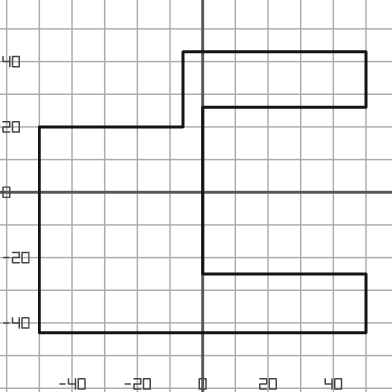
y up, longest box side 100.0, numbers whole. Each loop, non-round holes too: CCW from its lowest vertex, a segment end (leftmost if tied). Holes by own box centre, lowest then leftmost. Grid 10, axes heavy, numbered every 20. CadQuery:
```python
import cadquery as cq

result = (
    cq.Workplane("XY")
    .moveTo(-50.0, -43.0)
    .lineTo(50.0, -43.0)
    .lineTo(50.0, -25.0)
    .lineTo(0.0, -25.0)
    .lineTo(0.0, 26.0)
    .lineTo(50.0, 26.0)
    .lineTo(50.0, 43.0)
    .lineTo(-6.0, 43.0)
    .lineTo(-6.0, 20.0)
    .lineTo(-50.0, 20.0)
    .close()
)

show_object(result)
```